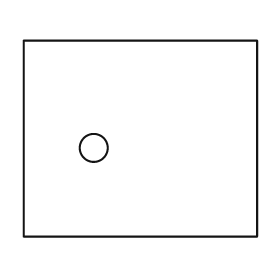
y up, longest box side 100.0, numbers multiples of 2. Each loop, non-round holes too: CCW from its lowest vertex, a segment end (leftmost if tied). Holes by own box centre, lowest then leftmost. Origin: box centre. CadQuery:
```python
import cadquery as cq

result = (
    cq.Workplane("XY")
    .moveTo(-50.0, -42.0)
    .lineTo(50.0, -42.0)
    .lineTo(50.0, 42.0)
    .lineTo(-50.0, 42.0)
    .close()
    .moveTo(-20.0, -4.0)
    .circle(6.0)
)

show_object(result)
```